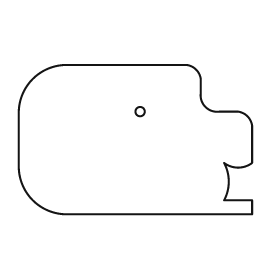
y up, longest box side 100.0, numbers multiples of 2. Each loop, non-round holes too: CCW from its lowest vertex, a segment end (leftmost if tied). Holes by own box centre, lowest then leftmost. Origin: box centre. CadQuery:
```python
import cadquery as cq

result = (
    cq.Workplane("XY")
    .moveTo(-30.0, -32.0)
    .lineTo(50.0, -32.0)
    .lineTo(50.0, -26.0)
    .lineTo(38.0, -26.0)
    .threePointArc((40.0, -18.0), (38.0, -10.0))
    .threePointArc((44.0, -12.0), (50.0, -10.0))
    .lineTo(50.0, 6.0)
    .threePointArc((48.0, 10.0), (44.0, 12.0))
    .lineTo(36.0, 12.0)
    .threePointArc((30.0, 14.0), (28.0, 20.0))
    .lineTo(28.0, 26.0)
    .threePointArc((26.0, 30.0), (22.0, 32.0))
    .lineTo(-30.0, 32.0)
    .threePointArc((-44.0, 26.0), (-50.0, 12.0))
    .lineTo(-50.0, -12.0)
    .threePointArc((-44.0, -26.0), (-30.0, -32.0))
    .close()
    .moveTo(2.0, 12.0)
    .circle(2.0)
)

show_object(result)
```